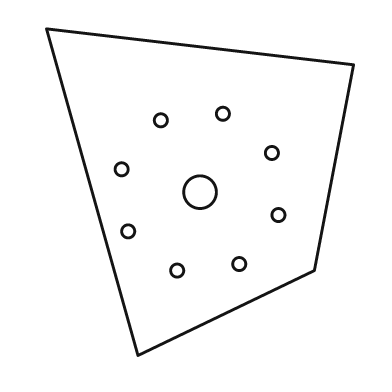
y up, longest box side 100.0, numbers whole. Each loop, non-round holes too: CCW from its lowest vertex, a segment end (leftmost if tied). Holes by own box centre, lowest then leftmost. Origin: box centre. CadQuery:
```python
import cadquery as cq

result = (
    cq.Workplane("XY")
    .moveTo(-19.0, -50.0)
    .lineTo(35.0, -24.0)
    .lineTo(47.0, 39.0)
    .lineTo(-47.0, 50.0)
    .close()
    .moveTo(-7.0, -24.0)
    .circle(2.0)
    .moveTo(12.0, -22.0)
    .circle(2.0)
    .moveTo(-22.0, -12.0)
    .circle(2.0)
    .moveTo(24.0, -7.0)
    .circle(2.0)
    .moveTo(0.0, 0.0)
    .circle(5.0)
    .moveTo(-24.0, 7.0)
    .circle(2.0)
    .moveTo(22.0, 12.0)
    .circle(2.0)
    .moveTo(-12.0, 22.0)
    .circle(2.0)
    .moveTo(7.0, 24.0)
    .circle(2.0)
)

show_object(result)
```